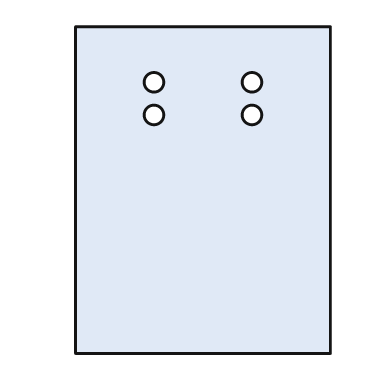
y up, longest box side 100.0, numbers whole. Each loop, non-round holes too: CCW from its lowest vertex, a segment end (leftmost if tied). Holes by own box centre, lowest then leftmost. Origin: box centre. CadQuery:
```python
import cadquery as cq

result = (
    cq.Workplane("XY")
    .moveTo(-39.0, -50.0)
    .lineTo(39.0, -50.0)
    .lineTo(39.0, 50.0)
    .lineTo(-39.0, 50.0)
    .close()
    .moveTo(-15.0, 23.0)
    .circle(3.0)
    .moveTo(15.0, 23.0)
    .circle(3.0)
    .moveTo(-15.0, 33.0)
    .circle(3.0)
    .moveTo(15.0, 33.0)
    .circle(3.0)
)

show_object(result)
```